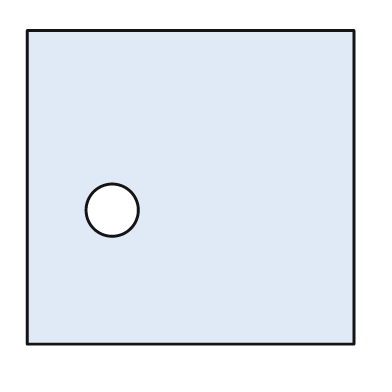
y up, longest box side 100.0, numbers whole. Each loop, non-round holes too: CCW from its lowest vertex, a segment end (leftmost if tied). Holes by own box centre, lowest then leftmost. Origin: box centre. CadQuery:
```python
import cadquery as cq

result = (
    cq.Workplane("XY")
    .moveTo(-50.0, -48.0)
    .lineTo(50.0, -48.0)
    .lineTo(50.0, 48.0)
    .lineTo(-50.0, 48.0)
    .close()
    .moveTo(-24.0, -7.0)
    .circle(8.0)
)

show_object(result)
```